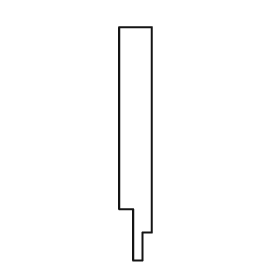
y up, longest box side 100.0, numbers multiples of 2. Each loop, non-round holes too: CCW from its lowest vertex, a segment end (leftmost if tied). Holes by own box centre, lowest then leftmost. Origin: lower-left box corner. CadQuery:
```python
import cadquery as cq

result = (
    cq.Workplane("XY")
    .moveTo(6.0, 0.0)
    .lineTo(10.0, 0.0)
    .lineTo(10.0, 12.0)
    .lineTo(14.0, 12.0)
    .lineTo(14.0, 100.0)
    .lineTo(0.0, 100.0)
    .lineTo(0.0, 22.0)
    .lineTo(6.0, 22.0)
    .close()
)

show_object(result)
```